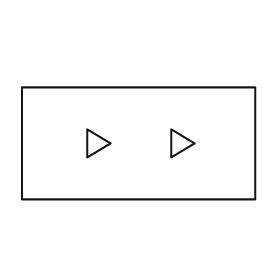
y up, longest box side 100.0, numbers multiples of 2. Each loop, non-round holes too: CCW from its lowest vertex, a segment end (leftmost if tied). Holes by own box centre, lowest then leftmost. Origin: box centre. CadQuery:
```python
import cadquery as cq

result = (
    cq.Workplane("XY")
    .moveTo(-50.0, -24.0)
    .lineTo(50.0, -24.0)
    .lineTo(50.0, 24.0)
    .lineTo(-50.0, 24.0)
    .close()
    .moveTo(-22.0, -6.0)
    .lineTo(-12.0, 0.0)
    .lineTo(-22.0, 6.0)
    .close()
    .moveTo(14.0, -6.0)
    .lineTo(24.0, 0.0)
    .lineTo(14.0, 6.0)
    .close()
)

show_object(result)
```